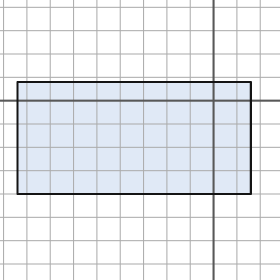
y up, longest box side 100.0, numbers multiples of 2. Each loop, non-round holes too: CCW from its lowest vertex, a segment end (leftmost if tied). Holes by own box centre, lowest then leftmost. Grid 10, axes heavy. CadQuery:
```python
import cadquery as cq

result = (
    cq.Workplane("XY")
    .moveTo(-84.0, -40.0)
    .lineTo(16.0, -40.0)
    .lineTo(16.0, 8.0)
    .lineTo(-84.0, 8.0)
    .close()
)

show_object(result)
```